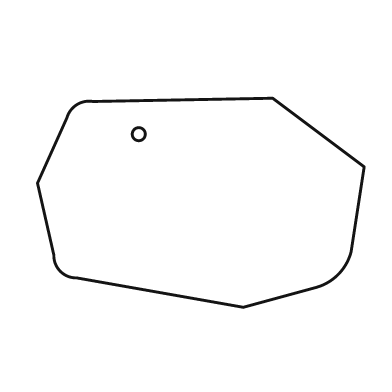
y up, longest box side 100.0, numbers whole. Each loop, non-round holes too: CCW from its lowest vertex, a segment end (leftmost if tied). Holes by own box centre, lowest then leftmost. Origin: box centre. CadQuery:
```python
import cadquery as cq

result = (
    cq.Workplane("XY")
    .moveTo(13.0, -32.0)
    .lineTo(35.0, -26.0)
    .threePointArc((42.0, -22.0), (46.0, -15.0))
    .lineTo(50.0, 11.0)
    .lineTo(22.0, 32.0)
    .lineTo(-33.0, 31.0)
    .threePointArc((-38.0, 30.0), (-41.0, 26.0))
    .lineTo(-50.0, 6.0)
    .lineTo(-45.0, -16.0)
    .threePointArc((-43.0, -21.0), (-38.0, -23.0))
    .close()
    .moveTo(-19.0, 21.0)
    .circle(2.0)
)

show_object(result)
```